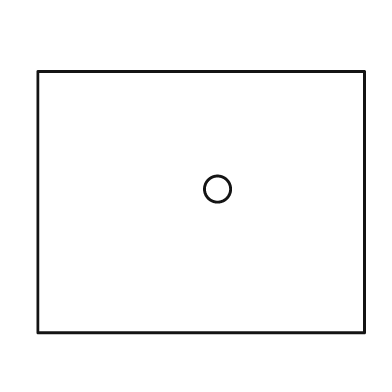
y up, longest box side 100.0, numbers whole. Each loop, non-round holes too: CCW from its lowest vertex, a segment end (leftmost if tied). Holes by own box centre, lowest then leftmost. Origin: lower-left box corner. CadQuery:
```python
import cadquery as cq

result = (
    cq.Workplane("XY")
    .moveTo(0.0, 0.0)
    .lineTo(100.0, 0.0)
    .lineTo(100.0, 80.0)
    .lineTo(0.0, 80.0)
    .close()
    .moveTo(55.0, 44.0)
    .circle(4.0)
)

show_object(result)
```